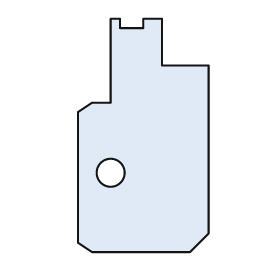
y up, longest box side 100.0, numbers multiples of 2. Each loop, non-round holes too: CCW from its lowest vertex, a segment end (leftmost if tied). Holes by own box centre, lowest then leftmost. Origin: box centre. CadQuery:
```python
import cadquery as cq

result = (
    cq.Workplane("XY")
    .moveTo(-22.0, -50.0)
    .lineTo(20.0, -50.0)
    .lineTo(28.0, -42.0)
    .lineTo(28.0, 30.0)
    .lineTo(8.0, 30.0)
    .lineTo(8.0, 50.0)
    .lineTo(0.0, 50.0)
    .lineTo(0.0, 46.0)
    .lineTo(-10.0, 46.0)
    .lineTo(-10.0, 50.0)
    .lineTo(-14.0, 50.0)
    .lineTo(-14.0, 14.0)
    .lineTo(-22.0, 14.0)
    .lineTo(-28.0, 10.0)
    .lineTo(-28.0, -46.0)
    .close()
    .moveTo(-14.0, -16.0)
    .circle(6.0)
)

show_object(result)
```